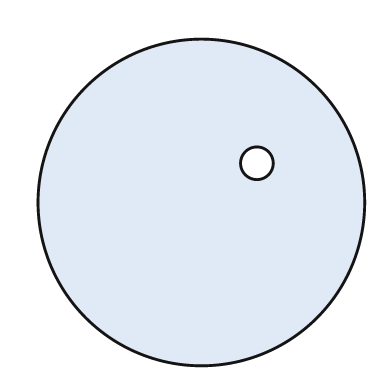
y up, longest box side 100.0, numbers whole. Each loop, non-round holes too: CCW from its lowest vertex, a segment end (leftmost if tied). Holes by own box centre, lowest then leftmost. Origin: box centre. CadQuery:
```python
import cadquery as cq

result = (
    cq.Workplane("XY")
    .moveTo(0.0, 0.0)
    .circle(50.0)
    .moveTo(17.0, 12.0)
    .circle(5.0)
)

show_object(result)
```